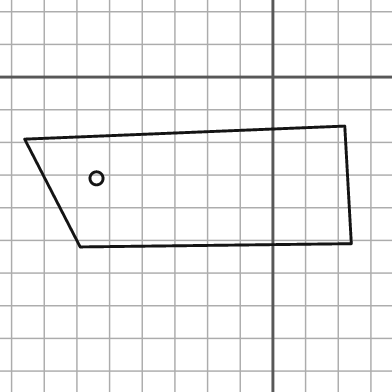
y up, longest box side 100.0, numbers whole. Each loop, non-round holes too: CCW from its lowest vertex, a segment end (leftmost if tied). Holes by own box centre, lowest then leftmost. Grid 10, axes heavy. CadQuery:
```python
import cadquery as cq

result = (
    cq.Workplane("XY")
    .moveTo(-59.0, -52.0)
    .lineTo(24.0, -51.0)
    .lineTo(22.0, -15.0)
    .lineTo(-76.0, -19.0)
    .close()
    .moveTo(-54.0, -31.0)
    .circle(2.0)
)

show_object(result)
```